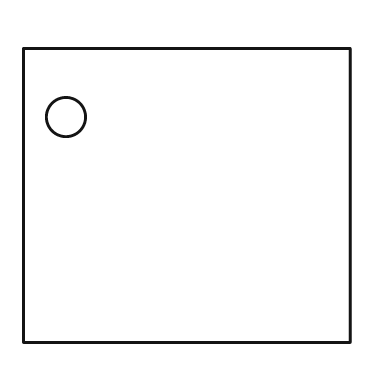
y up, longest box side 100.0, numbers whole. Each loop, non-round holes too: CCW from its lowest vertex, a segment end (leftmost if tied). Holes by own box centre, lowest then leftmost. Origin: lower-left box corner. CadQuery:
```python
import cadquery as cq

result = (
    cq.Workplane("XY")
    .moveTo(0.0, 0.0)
    .lineTo(100.0, 0.0)
    .lineTo(100.0, 90.0)
    .lineTo(0.0, 90.0)
    .close()
    .moveTo(13.0, 69.0)
    .circle(6.0)
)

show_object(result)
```